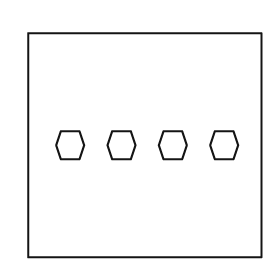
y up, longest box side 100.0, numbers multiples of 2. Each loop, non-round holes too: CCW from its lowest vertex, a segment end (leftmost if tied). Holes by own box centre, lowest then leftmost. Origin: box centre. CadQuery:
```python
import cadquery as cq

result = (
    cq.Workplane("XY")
    .moveTo(-50.0, -48.0)
    .lineTo(50.0, -48.0)
    .lineTo(50.0, 48.0)
    .lineTo(-50.0, 48.0)
    .close()
    .moveTo(-36.0, -6.0)
    .lineTo(-28.0, -6.0)
    .lineTo(-26.0, 0.0)
    .lineTo(-28.0, 6.0)
    .lineTo(-36.0, 6.0)
    .lineTo(-38.0, 0.0)
    .close()
    .moveTo(-14.0, -6.0)
    .lineTo(-6.0, -6.0)
    .lineTo(-4.0, 0.0)
    .lineTo(-6.0, 6.0)
    .lineTo(-14.0, 6.0)
    .lineTo(-16.0, 0.0)
    .close()
    .moveTo(8.0, -6.0)
    .lineTo(16.0, -6.0)
    .lineTo(18.0, 0.0)
    .lineTo(16.0, 6.0)
    .lineTo(8.0, 6.0)
    .lineTo(6.0, 0.0)
    .close()
    .moveTo(30.0, -6.0)
    .lineTo(38.0, -6.0)
    .lineTo(40.0, 0.0)
    .lineTo(38.0, 6.0)
    .lineTo(30.0, 6.0)
    .lineTo(28.0, 0.0)
    .close()
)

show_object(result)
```